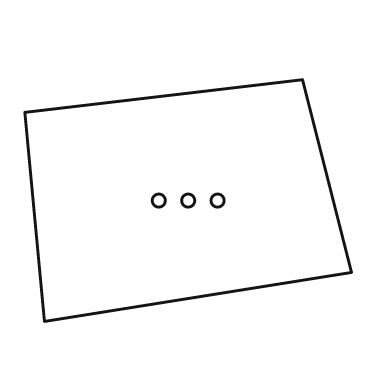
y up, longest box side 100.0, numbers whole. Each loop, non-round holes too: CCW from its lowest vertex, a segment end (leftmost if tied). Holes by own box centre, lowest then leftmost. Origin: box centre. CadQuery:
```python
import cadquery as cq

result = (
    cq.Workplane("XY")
    .moveTo(-44.0, -37.0)
    .lineTo(50.0, -22.0)
    .lineTo(35.0, 37.0)
    .lineTo(-50.0, 27.0)
    .close()
    .moveTo(-9.0, 0.0)
    .circle(2.0)
    .moveTo(0.0, 0.0)
    .circle(2.0)
    .moveTo(9.0, 0.0)
    .circle(2.0)
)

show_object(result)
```